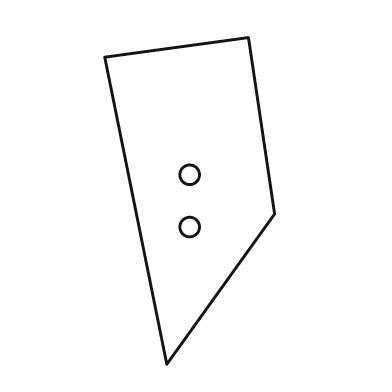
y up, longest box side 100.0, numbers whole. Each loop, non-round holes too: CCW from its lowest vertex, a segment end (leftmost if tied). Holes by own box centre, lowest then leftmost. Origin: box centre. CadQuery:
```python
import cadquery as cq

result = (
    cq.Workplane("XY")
    .moveTo(-7.0, -50.0)
    .lineTo(26.0, -4.0)
    .lineTo(18.0, 50.0)
    .lineTo(-26.0, 44.0)
    .close()
    .moveTo(0.0, -8.0)
    .circle(3.0)
    .moveTo(0.0, 8.0)
    .circle(3.0)
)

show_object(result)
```